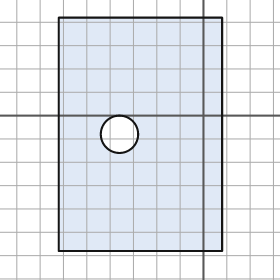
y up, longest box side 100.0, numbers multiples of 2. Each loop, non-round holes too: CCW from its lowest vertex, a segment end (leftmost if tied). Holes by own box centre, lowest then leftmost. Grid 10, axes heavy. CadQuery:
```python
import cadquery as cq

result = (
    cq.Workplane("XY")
    .moveTo(-62.0, -58.0)
    .lineTo(8.0, -58.0)
    .lineTo(8.0, 42.0)
    .lineTo(-62.0, 42.0)
    .close()
    .moveTo(-36.0, -8.0)
    .circle(8.0)
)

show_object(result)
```